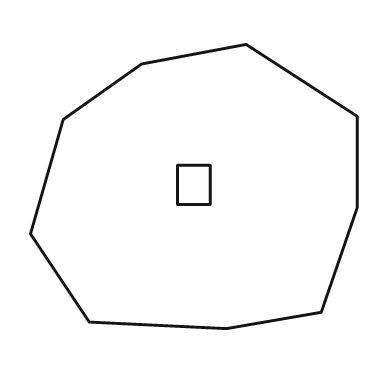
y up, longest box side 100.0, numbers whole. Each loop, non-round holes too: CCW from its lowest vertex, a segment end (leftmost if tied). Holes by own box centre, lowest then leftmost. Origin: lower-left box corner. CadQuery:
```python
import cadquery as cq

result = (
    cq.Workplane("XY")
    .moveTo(60.0, 0.0)
    .lineTo(89.0, 5.0)
    .lineTo(100.0, 37.0)
    .lineTo(100.0, 65.0)
    .lineTo(66.0, 87.0)
    .lineTo(34.0, 81.0)
    .lineTo(10.0, 64.0)
    .lineTo(0.0, 29.0)
    .lineTo(18.0, 2.0)
    .close()
    .moveTo(45.0, 38.0)
    .lineTo(55.0, 38.0)
    .lineTo(55.0, 50.0)
    .lineTo(45.0, 50.0)
    .close()
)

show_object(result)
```